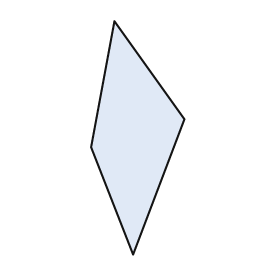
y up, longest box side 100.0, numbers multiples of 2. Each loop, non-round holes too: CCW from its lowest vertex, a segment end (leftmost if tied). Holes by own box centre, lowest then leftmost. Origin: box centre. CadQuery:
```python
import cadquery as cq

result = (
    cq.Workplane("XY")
    .moveTo(-2.0, -50.0)
    .lineTo(20.0, 8.0)
    .lineTo(-10.0, 50.0)
    .lineTo(-20.0, -4.0)
    .close()
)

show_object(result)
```